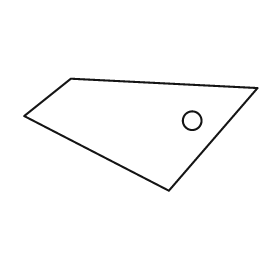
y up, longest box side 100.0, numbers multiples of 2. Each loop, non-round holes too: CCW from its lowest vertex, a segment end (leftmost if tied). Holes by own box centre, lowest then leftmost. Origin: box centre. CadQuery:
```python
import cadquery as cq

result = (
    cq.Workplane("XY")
    .moveTo(12.0, -24.0)
    .lineTo(50.0, 20.0)
    .lineTo(-30.0, 24.0)
    .lineTo(-50.0, 8.0)
    .close()
    .moveTo(22.0, 6.0)
    .circle(4.0)
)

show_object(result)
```